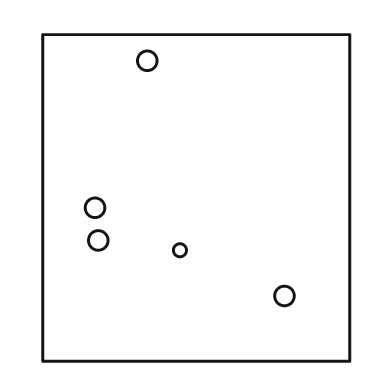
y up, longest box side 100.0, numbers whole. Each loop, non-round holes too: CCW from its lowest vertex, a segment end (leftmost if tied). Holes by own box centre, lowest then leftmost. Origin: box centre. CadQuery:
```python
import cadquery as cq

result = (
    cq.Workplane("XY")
    .moveTo(-47.0, -50.0)
    .lineTo(47.0, -50.0)
    .lineTo(47.0, 50.0)
    .lineTo(-47.0, 50.0)
    .close()
    .moveTo(27.0, -30.0)
    .circle(3.0)
    .moveTo(-5.0, -16.0)
    .circle(2.0)
    .moveTo(-30.0, -13.0)
    .circle(3.0)
    .moveTo(-31.0, -3.0)
    .circle(3.0)
    .moveTo(-15.0, 42.0)
    .circle(3.0)
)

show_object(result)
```